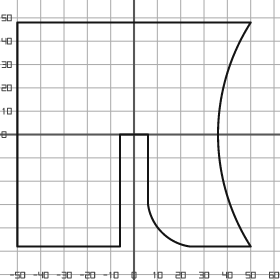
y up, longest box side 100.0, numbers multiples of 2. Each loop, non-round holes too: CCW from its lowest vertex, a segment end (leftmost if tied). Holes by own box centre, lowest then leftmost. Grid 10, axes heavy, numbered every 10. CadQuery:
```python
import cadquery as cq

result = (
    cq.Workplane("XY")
    .moveTo(-50.0, -48.0)
    .lineTo(-6.0, -48.0)
    .lineTo(-6.0, 0.0)
    .lineTo(6.0, 0.0)
    .lineTo(6.0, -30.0)
    .threePointArc((12.0, -42.0), (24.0, -48.0))
    .lineTo(50.0, -48.0)
    .threePointArc((36.0, 0.0), (50.0, 48.0))
    .lineTo(-50.0, 48.0)
    .close()
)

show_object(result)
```